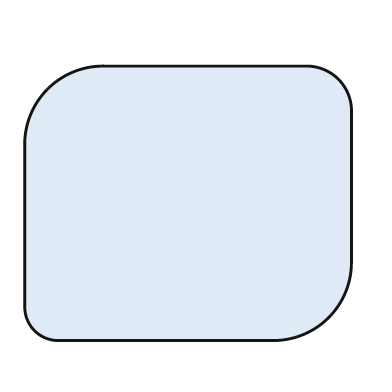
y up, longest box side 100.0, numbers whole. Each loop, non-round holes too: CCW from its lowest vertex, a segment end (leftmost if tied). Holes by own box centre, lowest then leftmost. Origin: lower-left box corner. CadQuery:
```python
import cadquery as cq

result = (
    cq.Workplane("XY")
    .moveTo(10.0, 0.0)
    .lineTo(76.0, 0.0)
    .threePointArc((93.0, 7.0), (100.0, 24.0))
    .lineTo(100.0, 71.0)
    .threePointArc((96.0, 80.0), (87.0, 84.0))
    .lineTo(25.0, 84.0)
    .threePointArc((7.0, 77.0), (0.0, 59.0))
    .lineTo(0.0, 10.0)
    .threePointArc((3.0, 3.0), (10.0, 0.0))
    .close()
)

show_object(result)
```